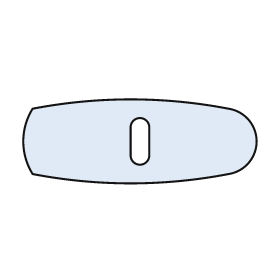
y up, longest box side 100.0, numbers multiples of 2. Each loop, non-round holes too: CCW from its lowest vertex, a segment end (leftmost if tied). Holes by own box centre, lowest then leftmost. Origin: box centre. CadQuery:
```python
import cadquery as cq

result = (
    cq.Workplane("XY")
    .moveTo(-46.0, -14.0)
    .threePointArc((-4.0, -18.0), (38.0, -14.0))
    .threePointArc((50.0, 0.0), (38.0, 14.0))
    .threePointArc((-4.0, 18.0), (-46.0, 14.0))
    .threePointArc((-50.0, 0.0), (-46.0, -14.0))
    .close()
    .moveTo(-4.0, -6.0)
    .threePointArc((0.0, -10.0), (4.0, -6.0))
    .lineTo(4.0, 6.0)
    .threePointArc((0.0, 10.0), (-4.0, 6.0))
    .close()
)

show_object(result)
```